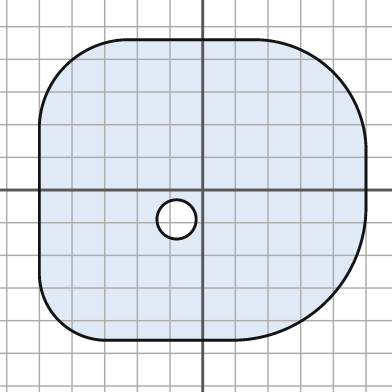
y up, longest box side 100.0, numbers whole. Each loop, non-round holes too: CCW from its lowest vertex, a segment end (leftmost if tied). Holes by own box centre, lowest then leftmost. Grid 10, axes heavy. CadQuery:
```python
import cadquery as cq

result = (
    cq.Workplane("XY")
    .moveTo(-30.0, -46.0)
    .lineTo(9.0, -46.0)
    .threePointArc((38.0, -34.0), (50.0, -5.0))
    .lineTo(50.0, 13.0)
    .threePointArc((40.0, 36.0), (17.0, 46.0))
    .lineTo(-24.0, 46.0)
    .threePointArc((-42.0, 38.0), (-50.0, 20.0))
    .lineTo(-50.0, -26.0)
    .threePointArc((-44.0, -40.0), (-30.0, -46.0))
    .close()
    .moveTo(-8.0, -9.0)
    .circle(6.0)
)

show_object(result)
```